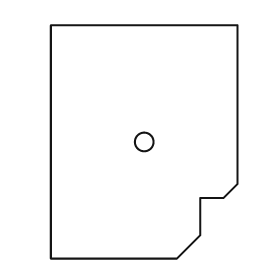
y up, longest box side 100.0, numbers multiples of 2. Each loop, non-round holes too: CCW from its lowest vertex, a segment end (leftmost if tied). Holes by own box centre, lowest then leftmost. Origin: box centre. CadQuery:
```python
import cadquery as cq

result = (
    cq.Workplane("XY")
    .moveTo(-40.0, -50.0)
    .lineTo(14.0, -50.0)
    .lineTo(24.0, -40.0)
    .lineTo(24.0, -24.0)
    .lineTo(34.0, -24.0)
    .lineTo(40.0, -18.0)
    .lineTo(40.0, 50.0)
    .lineTo(-40.0, 50.0)
    .close()
    .moveTo(0.0, 0.0)
    .circle(4.0)
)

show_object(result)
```